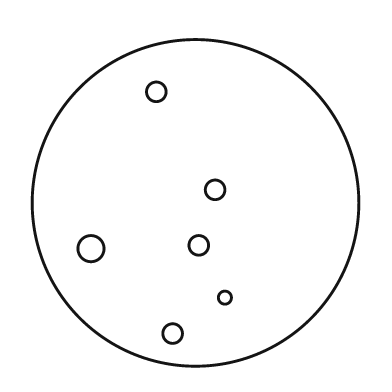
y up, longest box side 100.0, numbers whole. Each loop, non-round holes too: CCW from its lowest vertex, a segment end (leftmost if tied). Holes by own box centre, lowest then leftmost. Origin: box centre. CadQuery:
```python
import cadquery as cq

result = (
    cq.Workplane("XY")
    .moveTo(0.0, 0.0)
    .circle(50.0)
    .moveTo(-7.0, -40.0)
    .circle(3.0)
    .moveTo(9.0, -29.0)
    .circle(2.0)
    .moveTo(-32.0, -14.0)
    .circle(4.0)
    .moveTo(1.0, -13.0)
    .circle(3.0)
    .moveTo(6.0, 4.0)
    .circle(3.0)
    .moveTo(-12.0, 34.0)
    .circle(3.0)
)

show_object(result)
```